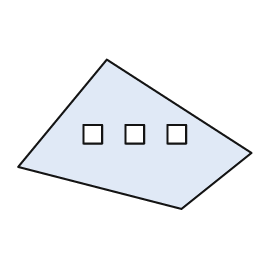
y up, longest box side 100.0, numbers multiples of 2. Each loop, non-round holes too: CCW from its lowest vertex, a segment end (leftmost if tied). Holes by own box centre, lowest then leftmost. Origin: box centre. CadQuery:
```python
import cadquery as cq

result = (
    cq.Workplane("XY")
    .moveTo(20.0, -32.0)
    .lineTo(50.0, -8.0)
    .lineTo(-12.0, 32.0)
    .lineTo(-50.0, -14.0)
    .close()
    .moveTo(-22.0, -4.0)
    .lineTo(-14.0, -4.0)
    .lineTo(-14.0, 4.0)
    .lineTo(-22.0, 4.0)
    .close()
    .moveTo(-4.0, -4.0)
    .lineTo(4.0, -4.0)
    .lineTo(4.0, 4.0)
    .lineTo(-4.0, 4.0)
    .close()
    .moveTo(14.0, -4.0)
    .lineTo(22.0, -4.0)
    .lineTo(22.0, 4.0)
    .lineTo(14.0, 4.0)
    .close()
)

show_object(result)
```